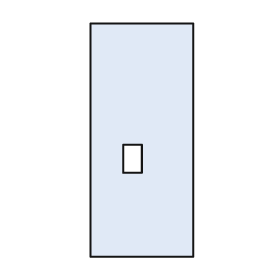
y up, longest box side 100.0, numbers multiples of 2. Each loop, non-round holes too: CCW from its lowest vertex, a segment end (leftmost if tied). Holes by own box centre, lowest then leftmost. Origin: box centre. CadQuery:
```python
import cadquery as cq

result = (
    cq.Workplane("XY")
    .moveTo(-22.0, -50.0)
    .lineTo(22.0, -50.0)
    .lineTo(22.0, 50.0)
    .lineTo(-22.0, 50.0)
    .close()
    .moveTo(-8.0, -14.0)
    .lineTo(0.0, -14.0)
    .lineTo(0.0, -2.0)
    .lineTo(-8.0, -2.0)
    .close()
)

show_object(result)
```